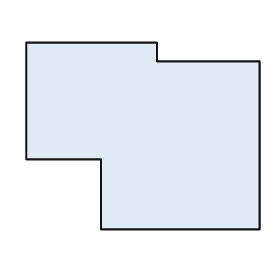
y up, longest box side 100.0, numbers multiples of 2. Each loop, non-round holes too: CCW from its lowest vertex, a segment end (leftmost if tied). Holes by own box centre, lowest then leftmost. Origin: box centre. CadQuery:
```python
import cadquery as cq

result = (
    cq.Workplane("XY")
    .moveTo(-18.0, -40.0)
    .lineTo(50.0, -40.0)
    .lineTo(50.0, 32.0)
    .lineTo(6.0, 32.0)
    .lineTo(6.0, 40.0)
    .lineTo(-50.0, 40.0)
    .lineTo(-50.0, -10.0)
    .lineTo(-18.0, -10.0)
    .close()
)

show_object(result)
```